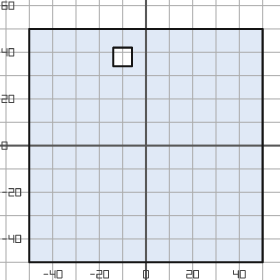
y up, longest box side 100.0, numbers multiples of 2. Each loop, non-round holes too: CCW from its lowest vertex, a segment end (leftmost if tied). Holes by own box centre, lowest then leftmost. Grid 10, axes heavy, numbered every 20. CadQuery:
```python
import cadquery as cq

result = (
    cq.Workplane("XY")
    .moveTo(-50.0, -50.0)
    .lineTo(50.0, -50.0)
    .lineTo(50.0, 50.0)
    .lineTo(-50.0, 50.0)
    .close()
    .moveTo(-14.0, 34.0)
    .lineTo(-6.0, 34.0)
    .lineTo(-6.0, 42.0)
    .lineTo(-14.0, 42.0)
    .close()
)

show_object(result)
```